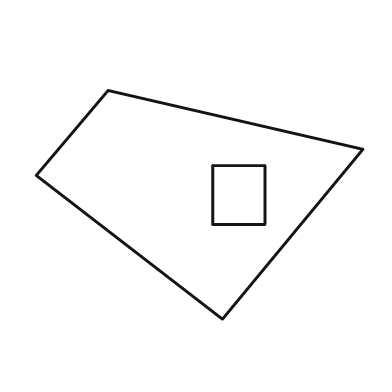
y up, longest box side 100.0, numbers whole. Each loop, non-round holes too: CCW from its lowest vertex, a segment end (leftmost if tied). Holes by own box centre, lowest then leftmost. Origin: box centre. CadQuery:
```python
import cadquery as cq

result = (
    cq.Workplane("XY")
    .moveTo(7.0, -35.0)
    .lineTo(50.0, 17.0)
    .lineTo(-28.0, 35.0)
    .lineTo(-50.0, 9.0)
    .close()
    .moveTo(4.0, -6.0)
    .lineTo(20.0, -6.0)
    .lineTo(20.0, 12.0)
    .lineTo(4.0, 12.0)
    .close()
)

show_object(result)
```